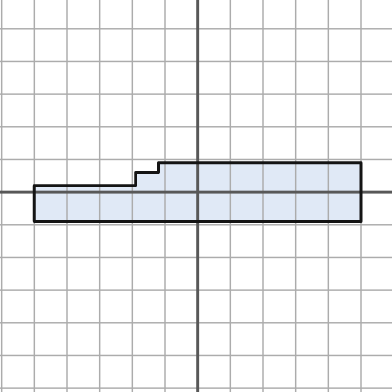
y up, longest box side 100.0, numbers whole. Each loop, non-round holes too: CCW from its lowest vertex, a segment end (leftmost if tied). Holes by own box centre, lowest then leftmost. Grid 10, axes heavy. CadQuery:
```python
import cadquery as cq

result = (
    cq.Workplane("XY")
    .moveTo(-50.0, -9.0)
    .lineTo(50.0, -9.0)
    .lineTo(50.0, 9.0)
    .lineTo(-12.0, 9.0)
    .lineTo(-12.0, 6.0)
    .lineTo(-19.0, 6.0)
    .lineTo(-19.0, 2.0)
    .lineTo(-50.0, 2.0)
    .close()
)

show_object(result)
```